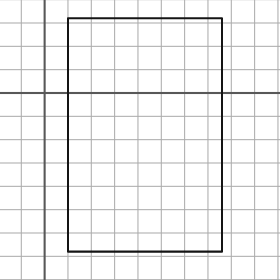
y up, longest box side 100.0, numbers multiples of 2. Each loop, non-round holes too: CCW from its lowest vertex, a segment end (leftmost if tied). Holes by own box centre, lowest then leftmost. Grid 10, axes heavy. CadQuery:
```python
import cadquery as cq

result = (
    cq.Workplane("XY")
    .moveTo(10.0, -68.0)
    .lineTo(76.0, -68.0)
    .lineTo(76.0, 32.0)
    .lineTo(10.0, 32.0)
    .close()
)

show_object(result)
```